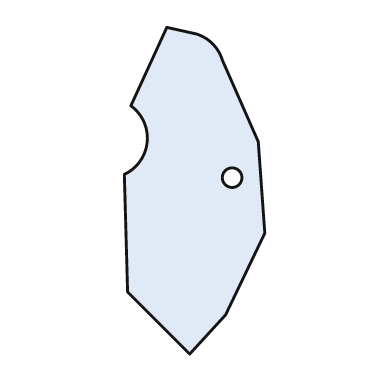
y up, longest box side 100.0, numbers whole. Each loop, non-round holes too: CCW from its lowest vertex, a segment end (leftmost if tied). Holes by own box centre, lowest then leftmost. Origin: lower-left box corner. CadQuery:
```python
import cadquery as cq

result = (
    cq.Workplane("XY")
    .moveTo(20.0, 0.0)
    .lineTo(31.0, 12.0)
    .lineTo(43.0, 37.0)
    .lineTo(41.0, 65.0)
    .lineTo(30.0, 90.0)
    .threePointArc((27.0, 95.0), (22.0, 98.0))
    .lineTo(13.0, 100.0)
    .lineTo(2.0, 76.0)
    .threePointArc((7.0, 65.0), (0.0, 55.0))
    .lineTo(1.0, 19.0)
    .close()
    .moveTo(33.0, 54.0)
    .circle(3.0)
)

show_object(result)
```